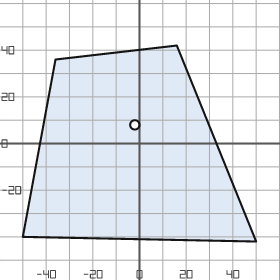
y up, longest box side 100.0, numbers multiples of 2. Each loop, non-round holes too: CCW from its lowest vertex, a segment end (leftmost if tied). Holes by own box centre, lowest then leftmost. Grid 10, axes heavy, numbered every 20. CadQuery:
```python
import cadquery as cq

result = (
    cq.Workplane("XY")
    .moveTo(50.0, -42.0)
    .lineTo(16.0, 42.0)
    .lineTo(-36.0, 36.0)
    .lineTo(-50.0, -40.0)
    .close()
    .moveTo(-2.0, 8.0)
    .circle(2.0)
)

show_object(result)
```